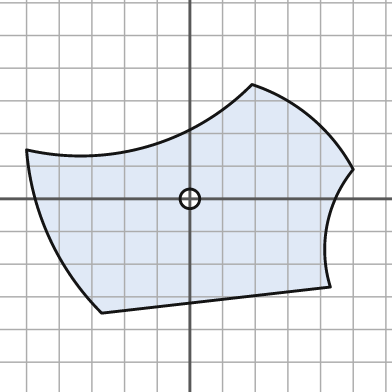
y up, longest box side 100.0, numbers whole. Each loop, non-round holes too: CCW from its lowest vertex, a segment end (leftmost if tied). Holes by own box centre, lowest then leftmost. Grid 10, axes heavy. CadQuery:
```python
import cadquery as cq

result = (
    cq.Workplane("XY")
    .moveTo(-27.0, -35.0)
    .lineTo(43.0, -27.0)
    .threePointArc((42.0, -8.0), (50.0, 9.0))
    .threePointArc((37.0, 25.0), (19.0, 35.0))
    .threePointArc((-13.0, 16.0), (-50.0, 15.0))
    .threePointArc((-43.0, -12.0), (-27.0, -35.0))
    .close()
    .moveTo(0.0, 0.0)
    .circle(3.0)
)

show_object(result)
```